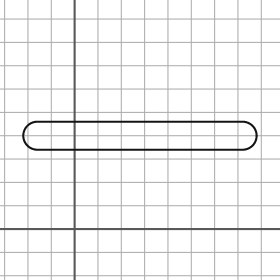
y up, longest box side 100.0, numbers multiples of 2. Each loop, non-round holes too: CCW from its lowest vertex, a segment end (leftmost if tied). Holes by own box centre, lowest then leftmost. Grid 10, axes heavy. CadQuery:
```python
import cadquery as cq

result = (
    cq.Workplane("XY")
    .moveTo(-16.0, 34.0)
    .lineTo(72.0, 34.0)
    .threePointArc((78.0, 40.0), (72.0, 46.0))
    .lineTo(-16.0, 46.0)
    .threePointArc((-22.0, 40.0), (-16.0, 34.0))
    .close()
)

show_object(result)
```